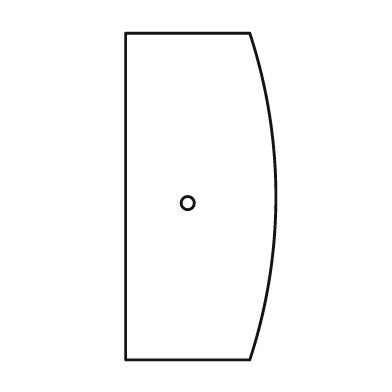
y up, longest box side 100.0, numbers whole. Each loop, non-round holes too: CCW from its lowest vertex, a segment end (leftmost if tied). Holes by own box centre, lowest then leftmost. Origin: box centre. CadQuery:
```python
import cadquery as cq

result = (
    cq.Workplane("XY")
    .moveTo(-23.0, -50.0)
    .lineTo(15.0, -50.0)
    .threePointArc((23.0, 0.0), (15.0, 50.0))
    .lineTo(-23.0, 50.0)
    .close()
    .moveTo(-4.0, -2.0)
    .circle(2.0)
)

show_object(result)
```